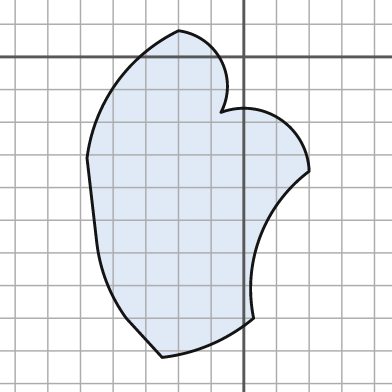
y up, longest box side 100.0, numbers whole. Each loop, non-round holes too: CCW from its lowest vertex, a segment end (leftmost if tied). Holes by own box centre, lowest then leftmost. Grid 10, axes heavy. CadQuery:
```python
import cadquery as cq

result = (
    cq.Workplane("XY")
    .moveTo(-25.0, -92.0)
    .threePointArc((-10.0, -88.0), (3.0, -80.0))
    .threePointArc((5.0, -55.0), (20.0, -35.0))
    .threePointArc((11.0, -19.0), (-7.0, -17.0))
    .threePointArc((-7.0, -1.0), (-20.0, 8.0))
    .threePointArc((-39.0, -8.0), (-48.0, -31.0))
    .lineTo(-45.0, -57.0)
    .threePointArc((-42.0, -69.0), (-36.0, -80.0))
    .close()
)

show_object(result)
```